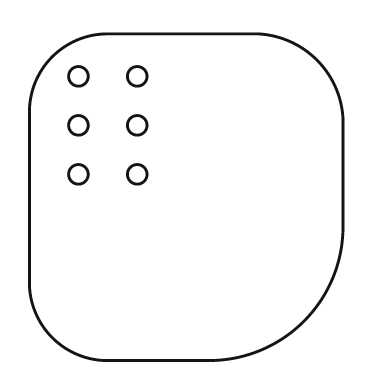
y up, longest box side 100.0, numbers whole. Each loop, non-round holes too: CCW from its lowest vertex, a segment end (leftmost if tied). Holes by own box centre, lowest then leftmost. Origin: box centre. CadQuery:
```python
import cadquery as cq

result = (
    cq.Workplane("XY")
    .moveTo(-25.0, -50.0)
    .lineTo(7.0, -50.0)
    .threePointArc((36.0, -38.0), (48.0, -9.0))
    .lineTo(48.0, 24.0)
    .threePointArc((40.0, 42.0), (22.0, 50.0))
    .lineTo(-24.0, 50.0)
    .threePointArc((-41.0, 43.0), (-48.0, 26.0))
    .lineTo(-48.0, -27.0)
    .threePointArc((-41.0, -43.0), (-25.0, -50.0))
    .close()
    .moveTo(-33.0, 7.0)
    .circle(3.0)
    .moveTo(-15.0, 7.0)
    .circle(3.0)
    .moveTo(-33.0, 22.0)
    .circle(3.0)
    .moveTo(-15.0, 22.0)
    .circle(3.0)
    .moveTo(-33.0, 37.0)
    .circle(3.0)
    .moveTo(-15.0, 37.0)
    .circle(3.0)
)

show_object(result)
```